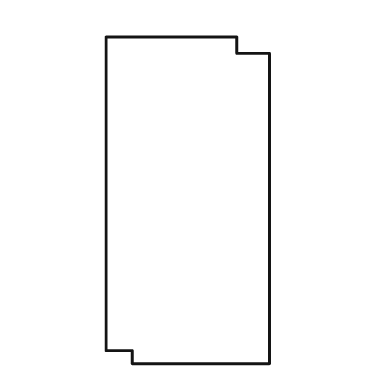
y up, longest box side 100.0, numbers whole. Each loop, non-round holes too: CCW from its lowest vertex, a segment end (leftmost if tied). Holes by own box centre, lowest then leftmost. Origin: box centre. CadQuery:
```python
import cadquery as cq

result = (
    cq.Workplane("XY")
    .moveTo(-17.0, -50.0)
    .lineTo(25.0, -50.0)
    .lineTo(25.0, 45.0)
    .lineTo(15.0, 45.0)
    .lineTo(15.0, 50.0)
    .lineTo(-25.0, 50.0)
    .lineTo(-25.0, -46.0)
    .lineTo(-17.0, -46.0)
    .close()
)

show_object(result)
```